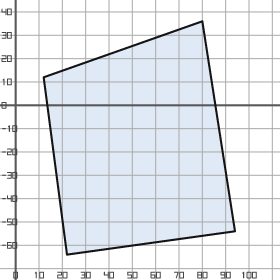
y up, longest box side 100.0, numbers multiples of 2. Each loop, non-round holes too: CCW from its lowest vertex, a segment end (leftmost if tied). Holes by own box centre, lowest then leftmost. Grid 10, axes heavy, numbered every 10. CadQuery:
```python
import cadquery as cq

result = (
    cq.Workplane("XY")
    .moveTo(22.0, -64.0)
    .lineTo(94.0, -54.0)
    .lineTo(80.0, 36.0)
    .lineTo(12.0, 12.0)
    .close()
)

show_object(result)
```